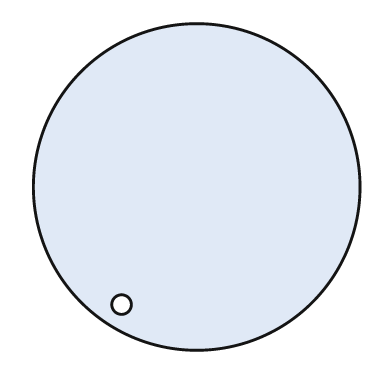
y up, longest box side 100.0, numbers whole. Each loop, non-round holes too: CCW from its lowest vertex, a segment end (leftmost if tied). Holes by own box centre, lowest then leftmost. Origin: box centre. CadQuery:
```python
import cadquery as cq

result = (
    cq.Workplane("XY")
    .moveTo(0.0, 0.0)
    .circle(50.0)
    .moveTo(-23.0, -36.0)
    .circle(3.0)
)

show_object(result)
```